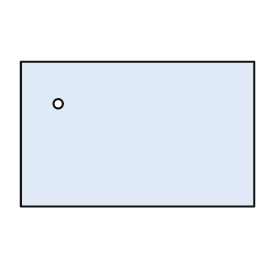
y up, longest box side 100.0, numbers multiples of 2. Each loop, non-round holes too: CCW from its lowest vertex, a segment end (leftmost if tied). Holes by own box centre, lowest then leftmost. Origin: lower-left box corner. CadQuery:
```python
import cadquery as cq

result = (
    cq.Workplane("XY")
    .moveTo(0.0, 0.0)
    .lineTo(100.0, 0.0)
    .lineTo(100.0, 62.0)
    .lineTo(0.0, 62.0)
    .close()
    .moveTo(16.0, 44.0)
    .circle(2.0)
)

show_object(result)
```